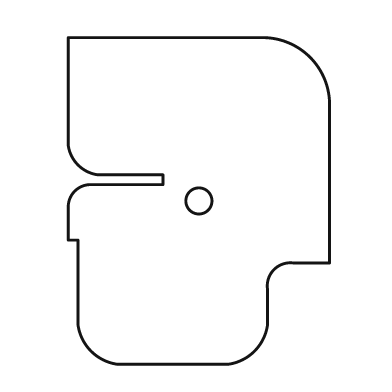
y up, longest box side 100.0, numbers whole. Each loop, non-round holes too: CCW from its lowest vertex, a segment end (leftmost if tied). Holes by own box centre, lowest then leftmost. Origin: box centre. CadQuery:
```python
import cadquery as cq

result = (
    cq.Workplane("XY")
    .moveTo(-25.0, -50.0)
    .lineTo(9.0, -50.0)
    .threePointArc((17.0, -46.0), (21.0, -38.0))
    .lineTo(21.0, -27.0)
    .threePointArc((23.0, -21.0), (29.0, -19.0))
    .lineTo(40.0, -19.0)
    .lineTo(40.0, 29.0)
    .threePointArc((34.0, 44.0), (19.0, 50.0))
    .lineTo(-40.0, 50.0)
    .lineTo(-40.0, 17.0)
    .threePointArc((-37.0, 11.0), (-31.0, 8.0))
    .lineTo(-11.0, 8.0)
    .lineTo(-11.0, 5.0)
    .lineTo(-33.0, 5.0)
    .threePointArc((-38.0, 3.0), (-40.0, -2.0))
    .lineTo(-40.0, -12.0)
    .lineTo(-37.0, -12.0)
    .lineTo(-37.0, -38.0)
    .threePointArc((-33.0, -46.0), (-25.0, -50.0))
    .close()
    .moveTo(0.0, 0.0)
    .circle(4.0)
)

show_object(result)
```